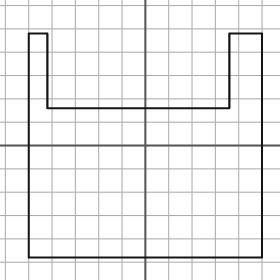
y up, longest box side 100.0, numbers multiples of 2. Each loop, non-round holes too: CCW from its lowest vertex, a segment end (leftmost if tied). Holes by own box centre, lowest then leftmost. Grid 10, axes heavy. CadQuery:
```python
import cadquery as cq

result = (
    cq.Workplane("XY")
    .moveTo(-50.0, -48.0)
    .lineTo(50.0, -48.0)
    .lineTo(50.0, 48.0)
    .lineTo(36.0, 48.0)
    .lineTo(36.0, 16.0)
    .lineTo(-42.0, 16.0)
    .lineTo(-42.0, 48.0)
    .lineTo(-50.0, 48.0)
    .close()
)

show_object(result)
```